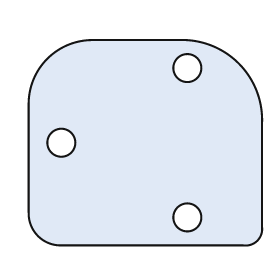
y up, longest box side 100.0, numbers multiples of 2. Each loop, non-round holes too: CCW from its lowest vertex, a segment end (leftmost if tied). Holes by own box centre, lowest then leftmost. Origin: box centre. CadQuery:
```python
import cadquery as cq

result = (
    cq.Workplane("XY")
    .moveTo(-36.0, -44.0)
    .lineTo(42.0, -44.0)
    .threePointArc((48.0, -42.0), (50.0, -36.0))
    .lineTo(50.0, 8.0)
    .threePointArc((40.0, 34.0), (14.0, 44.0))
    .lineTo(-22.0, 44.0)
    .threePointArc((-42.0, 36.0), (-50.0, 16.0))
    .lineTo(-50.0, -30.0)
    .threePointArc((-46.0, -40.0), (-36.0, -44.0))
    .close()
    .moveTo(18.0, -32.0)
    .circle(6.0)
    .moveTo(-36.0, 0.0)
    .circle(6.0)
    .moveTo(18.0, 32.0)
    .circle(6.0)
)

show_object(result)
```